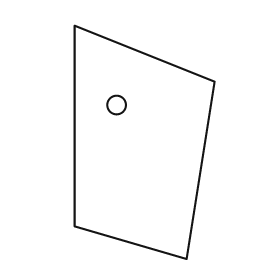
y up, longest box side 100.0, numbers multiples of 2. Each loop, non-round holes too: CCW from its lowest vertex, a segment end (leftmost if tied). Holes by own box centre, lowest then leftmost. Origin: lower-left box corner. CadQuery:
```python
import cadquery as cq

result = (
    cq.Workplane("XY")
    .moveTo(48.0, 0.0)
    .lineTo(60.0, 76.0)
    .lineTo(0.0, 100.0)
    .lineTo(0.0, 14.0)
    .close()
    .moveTo(18.0, 66.0)
    .circle(4.0)
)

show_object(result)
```